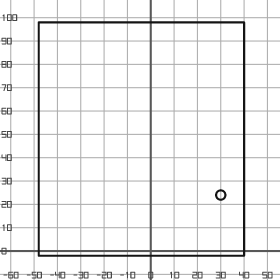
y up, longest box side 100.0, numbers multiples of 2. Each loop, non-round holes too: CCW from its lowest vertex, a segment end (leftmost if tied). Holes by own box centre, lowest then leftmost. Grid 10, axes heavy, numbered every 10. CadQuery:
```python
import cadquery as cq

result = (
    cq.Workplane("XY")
    .moveTo(-48.0, -2.0)
    .lineTo(40.0, -2.0)
    .lineTo(40.0, 98.0)
    .lineTo(-48.0, 98.0)
    .close()
    .moveTo(30.0, 24.0)
    .circle(2.0)
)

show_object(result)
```